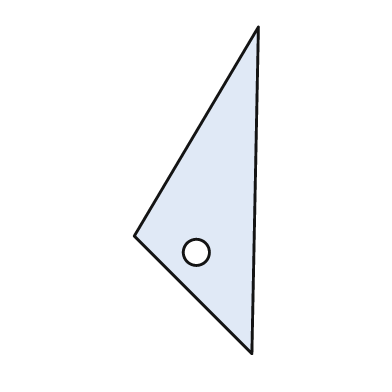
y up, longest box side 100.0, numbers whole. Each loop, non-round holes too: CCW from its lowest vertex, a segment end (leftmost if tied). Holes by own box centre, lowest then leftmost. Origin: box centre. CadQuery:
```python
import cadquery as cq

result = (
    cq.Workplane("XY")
    .moveTo(17.0, -50.0)
    .lineTo(19.0, 50.0)
    .lineTo(-19.0, -14.0)
    .close()
    .moveTo(0.0, -19.0)
    .circle(4.0)
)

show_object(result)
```